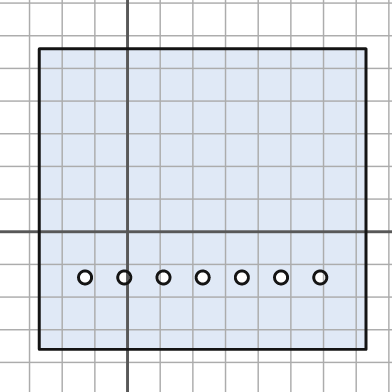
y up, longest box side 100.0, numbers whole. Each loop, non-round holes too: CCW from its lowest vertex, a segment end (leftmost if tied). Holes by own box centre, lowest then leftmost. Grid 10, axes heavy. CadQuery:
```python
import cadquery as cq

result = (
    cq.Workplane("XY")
    .moveTo(-27.0, -36.0)
    .lineTo(73.0, -36.0)
    .lineTo(73.0, 56.0)
    .lineTo(-27.0, 56.0)
    .close()
    .moveTo(-13.0, -14.0)
    .circle(2.0)
    .moveTo(-1.0, -14.0)
    .circle(2.0)
    .moveTo(11.0, -14.0)
    .circle(2.0)
    .moveTo(23.0, -14.0)
    .circle(2.0)
    .moveTo(35.0, -14.0)
    .circle(2.0)
    .moveTo(47.0, -14.0)
    .circle(2.0)
    .moveTo(59.0, -14.0)
    .circle(2.0)
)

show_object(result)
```